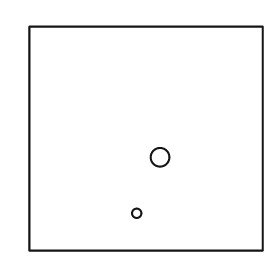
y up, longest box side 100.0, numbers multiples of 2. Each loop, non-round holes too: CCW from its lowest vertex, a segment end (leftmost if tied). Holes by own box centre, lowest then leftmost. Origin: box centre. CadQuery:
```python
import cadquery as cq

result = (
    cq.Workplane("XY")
    .moveTo(-50.0, -48.0)
    .lineTo(50.0, -48.0)
    .lineTo(50.0, 48.0)
    .lineTo(-50.0, 48.0)
    .close()
    .moveTo(-4.0, -32.0)
    .circle(2.0)
    .moveTo(6.0, -8.0)
    .circle(4.0)
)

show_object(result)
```